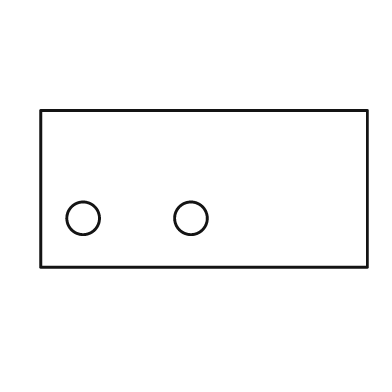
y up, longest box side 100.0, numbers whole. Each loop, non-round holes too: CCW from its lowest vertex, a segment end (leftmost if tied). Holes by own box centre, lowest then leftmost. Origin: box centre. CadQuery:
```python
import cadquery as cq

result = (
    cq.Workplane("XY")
    .moveTo(-50.0, -24.0)
    .lineTo(50.0, -24.0)
    .lineTo(50.0, 24.0)
    .lineTo(-50.0, 24.0)
    .close()
    .moveTo(-37.0, -9.0)
    .circle(5.0)
    .moveTo(-4.0, -9.0)
    .circle(5.0)
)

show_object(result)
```